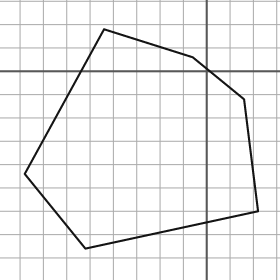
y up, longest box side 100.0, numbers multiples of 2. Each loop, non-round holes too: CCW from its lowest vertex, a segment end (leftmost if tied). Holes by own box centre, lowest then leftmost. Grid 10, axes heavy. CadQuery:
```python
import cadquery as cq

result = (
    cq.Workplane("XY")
    .moveTo(-52.0, -76.0)
    .lineTo(22.0, -60.0)
    .lineTo(16.0, -12.0)
    .lineTo(-6.0, 6.0)
    .lineTo(-44.0, 18.0)
    .lineTo(-78.0, -44.0)
    .close()
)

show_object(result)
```